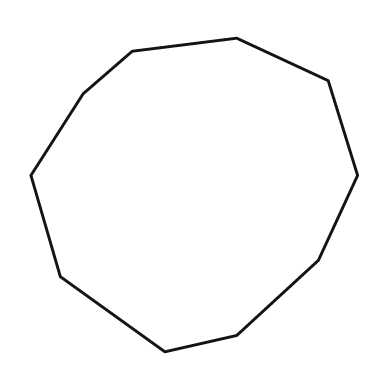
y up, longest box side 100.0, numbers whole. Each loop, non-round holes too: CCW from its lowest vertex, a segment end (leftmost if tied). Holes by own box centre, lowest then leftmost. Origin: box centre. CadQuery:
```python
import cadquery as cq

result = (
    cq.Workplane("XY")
    .moveTo(-9.0, -48.0)
    .lineTo(13.0, -43.0)
    .lineTo(38.0, -20.0)
    .lineTo(50.0, 6.0)
    .lineTo(41.0, 35.0)
    .lineTo(13.0, 48.0)
    .lineTo(-19.0, 44.0)
    .lineTo(-34.0, 31.0)
    .lineTo(-50.0, 6.0)
    .lineTo(-41.0, -25.0)
    .close()
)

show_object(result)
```